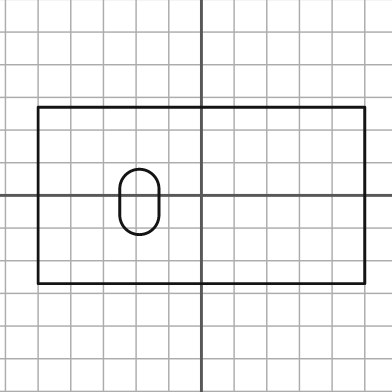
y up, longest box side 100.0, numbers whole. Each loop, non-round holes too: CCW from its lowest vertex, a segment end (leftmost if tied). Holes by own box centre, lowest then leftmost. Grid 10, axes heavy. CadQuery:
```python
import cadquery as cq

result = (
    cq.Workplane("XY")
    .moveTo(-50.0, -27.0)
    .lineTo(50.0, -27.0)
    .lineTo(50.0, 27.0)
    .lineTo(-50.0, 27.0)
    .close()
    .moveTo(-25.0, -6.0)
    .threePointArc((-19.0, -12.0), (-13.0, -6.0))
    .lineTo(-13.0, 2.0)
    .threePointArc((-19.0, 8.0), (-25.0, 2.0))
    .close()
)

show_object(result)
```